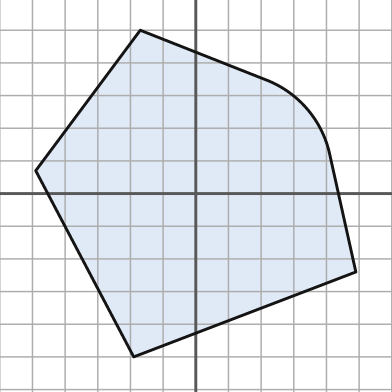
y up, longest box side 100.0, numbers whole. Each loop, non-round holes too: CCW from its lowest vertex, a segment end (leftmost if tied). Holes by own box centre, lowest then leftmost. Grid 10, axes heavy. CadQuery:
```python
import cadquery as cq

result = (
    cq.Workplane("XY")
    .moveTo(-19.0, -50.0)
    .lineTo(49.0, -24.0)
    .lineTo(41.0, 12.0)
    .threePointArc((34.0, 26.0), (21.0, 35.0))
    .lineTo(-17.0, 50.0)
    .lineTo(-49.0, 7.0)
    .close()
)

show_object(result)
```